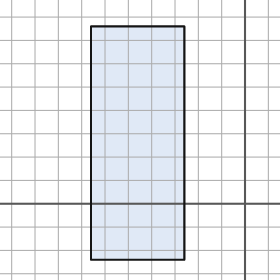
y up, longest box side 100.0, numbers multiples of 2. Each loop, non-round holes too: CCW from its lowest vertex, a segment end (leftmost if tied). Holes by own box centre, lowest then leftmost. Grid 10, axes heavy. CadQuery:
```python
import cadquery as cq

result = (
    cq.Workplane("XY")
    .moveTo(-66.0, -24.0)
    .lineTo(-26.0, -24.0)
    .lineTo(-26.0, 76.0)
    .lineTo(-66.0, 76.0)
    .close()
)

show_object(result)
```